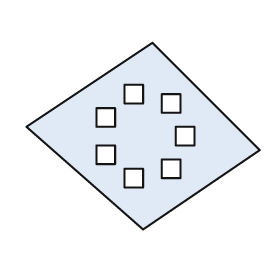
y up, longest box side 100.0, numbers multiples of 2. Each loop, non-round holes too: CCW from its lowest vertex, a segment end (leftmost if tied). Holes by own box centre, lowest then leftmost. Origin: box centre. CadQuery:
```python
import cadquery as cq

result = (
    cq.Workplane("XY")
    .moveTo(0.0, -40.0)
    .lineTo(50.0, -6.0)
    .lineTo(4.0, 40.0)
    .lineTo(-50.0, 4.0)
    .close()
    .moveTo(-8.0, -22.0)
    .lineTo(0.0, -22.0)
    .lineTo(0.0, -14.0)
    .lineTo(-8.0, -14.0)
    .close()
    .moveTo(8.0, -18.0)
    .lineTo(16.0, -18.0)
    .lineTo(16.0, -10.0)
    .lineTo(8.0, -10.0)
    .close()
    .moveTo(-20.0, -12.0)
    .lineTo(-12.0, -12.0)
    .lineTo(-12.0, -4.0)
    .lineTo(-20.0, -4.0)
    .close()
    .moveTo(14.0, -4.0)
    .lineTo(22.0, -4.0)
    .lineTo(22.0, 4.0)
    .lineTo(14.0, 4.0)
    .close()
    .moveTo(-20.0, 4.0)
    .lineTo(-12.0, 4.0)
    .lineTo(-12.0, 12.0)
    .lineTo(-20.0, 12.0)
    .close()
    .moveTo(8.0, 10.0)
    .lineTo(16.0, 10.0)
    .lineTo(16.0, 18.0)
    .lineTo(8.0, 18.0)
    .close()
    .moveTo(-8.0, 14.0)
    .lineTo(0.0, 14.0)
    .lineTo(0.0, 22.0)
    .lineTo(-8.0, 22.0)
    .close()
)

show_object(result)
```